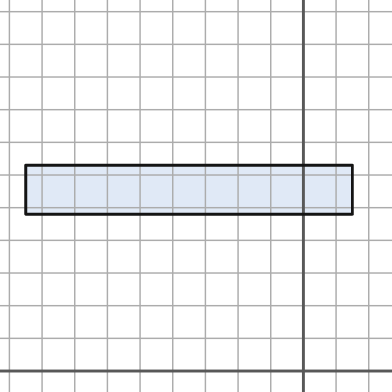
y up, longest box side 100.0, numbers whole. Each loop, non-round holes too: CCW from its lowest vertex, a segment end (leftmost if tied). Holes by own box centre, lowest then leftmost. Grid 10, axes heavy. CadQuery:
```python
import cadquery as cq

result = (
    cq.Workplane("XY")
    .moveTo(-85.0, 48.0)
    .lineTo(15.0, 48.0)
    .lineTo(15.0, 63.0)
    .lineTo(-85.0, 63.0)
    .close()
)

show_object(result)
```